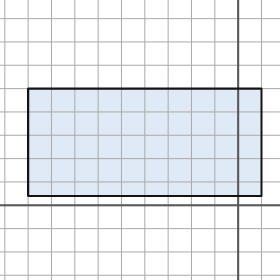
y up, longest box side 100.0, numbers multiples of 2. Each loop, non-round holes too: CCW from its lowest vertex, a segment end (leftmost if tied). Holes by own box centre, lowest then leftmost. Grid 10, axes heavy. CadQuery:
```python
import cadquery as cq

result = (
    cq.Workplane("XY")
    .moveTo(-90.0, 4.0)
    .lineTo(10.0, 4.0)
    .lineTo(10.0, 50.0)
    .lineTo(-90.0, 50.0)
    .close()
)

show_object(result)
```